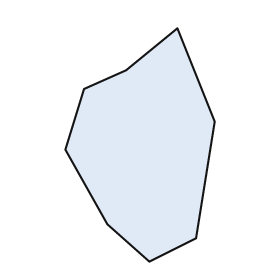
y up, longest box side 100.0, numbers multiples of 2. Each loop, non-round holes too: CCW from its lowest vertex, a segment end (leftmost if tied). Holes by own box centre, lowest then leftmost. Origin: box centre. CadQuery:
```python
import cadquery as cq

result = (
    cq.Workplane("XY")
    .moveTo(4.0, -50.0)
    .lineTo(24.0, -40.0)
    .lineTo(32.0, 10.0)
    .lineTo(16.0, 50.0)
    .lineTo(-6.0, 32.0)
    .lineTo(-24.0, 24.0)
    .lineTo(-32.0, -2.0)
    .lineTo(-14.0, -34.0)
    .close()
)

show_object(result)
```